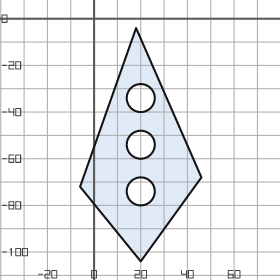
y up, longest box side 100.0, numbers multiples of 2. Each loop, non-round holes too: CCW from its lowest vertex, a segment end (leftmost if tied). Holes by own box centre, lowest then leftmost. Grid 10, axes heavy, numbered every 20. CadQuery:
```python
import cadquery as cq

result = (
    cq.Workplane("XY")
    .moveTo(20.0, -104.0)
    .lineTo(46.0, -68.0)
    .lineTo(18.0, -4.0)
    .lineTo(-6.0, -72.0)
    .close()
    .moveTo(20.0, -74.0)
    .circle(6.0)
    .moveTo(20.0, -54.0)
    .circle(6.0)
    .moveTo(20.0, -34.0)
    .circle(6.0)
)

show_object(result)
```